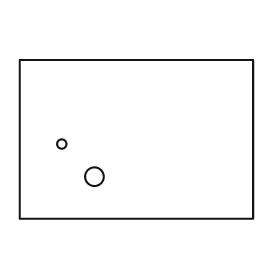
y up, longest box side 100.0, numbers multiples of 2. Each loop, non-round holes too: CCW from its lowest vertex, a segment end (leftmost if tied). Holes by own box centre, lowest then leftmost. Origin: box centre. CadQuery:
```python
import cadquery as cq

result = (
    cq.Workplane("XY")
    .moveTo(-50.0, -34.0)
    .lineTo(50.0, -34.0)
    .lineTo(50.0, 34.0)
    .lineTo(-50.0, 34.0)
    .close()
    .moveTo(-18.0, -16.0)
    .circle(4.0)
    .moveTo(-32.0, -2.0)
    .circle(2.0)
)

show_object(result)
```